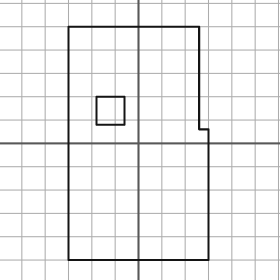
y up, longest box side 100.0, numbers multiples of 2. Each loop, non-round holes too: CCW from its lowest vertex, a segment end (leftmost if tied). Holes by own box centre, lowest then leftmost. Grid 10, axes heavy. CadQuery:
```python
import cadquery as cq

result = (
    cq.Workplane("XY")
    .moveTo(-30.0, -50.0)
    .lineTo(30.0, -50.0)
    .lineTo(30.0, 6.0)
    .lineTo(26.0, 6.0)
    .lineTo(26.0, 50.0)
    .lineTo(-30.0, 50.0)
    .close()
    .moveTo(-18.0, 8.0)
    .lineTo(-6.0, 8.0)
    .lineTo(-6.0, 20.0)
    .lineTo(-18.0, 20.0)
    .close()
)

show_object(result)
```